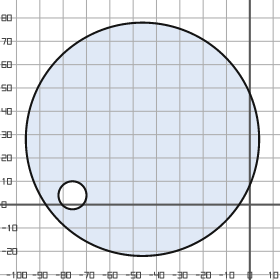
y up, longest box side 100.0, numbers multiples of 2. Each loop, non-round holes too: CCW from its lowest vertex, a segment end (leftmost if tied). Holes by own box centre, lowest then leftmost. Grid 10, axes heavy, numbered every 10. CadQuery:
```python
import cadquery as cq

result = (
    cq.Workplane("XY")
    .moveTo(-46.0, 28.0)
    .circle(50.0)
    .moveTo(-76.0, 4.0)
    .circle(6.0)
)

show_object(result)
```